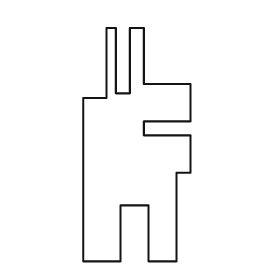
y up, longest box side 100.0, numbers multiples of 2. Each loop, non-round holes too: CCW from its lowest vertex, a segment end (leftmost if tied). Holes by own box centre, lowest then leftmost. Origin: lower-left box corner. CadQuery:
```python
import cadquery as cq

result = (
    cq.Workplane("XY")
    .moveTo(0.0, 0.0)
    .lineTo(16.0, 0.0)
    .lineTo(16.0, 24.0)
    .lineTo(28.0, 24.0)
    .lineTo(28.0, 0.0)
    .lineTo(40.0, 0.0)
    .lineTo(40.0, 38.0)
    .lineTo(46.0, 38.0)
    .lineTo(46.0, 54.0)
    .lineTo(26.0, 54.0)
    .lineTo(26.0, 60.0)
    .lineTo(46.0, 60.0)
    .lineTo(46.0, 76.0)
    .lineTo(26.0, 76.0)
    .lineTo(26.0, 100.0)
    .lineTo(20.0, 100.0)
    .lineTo(20.0, 72.0)
    .lineTo(14.0, 72.0)
    .lineTo(14.0, 100.0)
    .lineTo(10.0, 100.0)
    .lineTo(10.0, 70.0)
    .lineTo(0.0, 70.0)
    .close()
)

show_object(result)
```